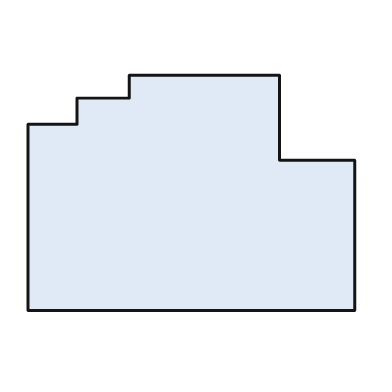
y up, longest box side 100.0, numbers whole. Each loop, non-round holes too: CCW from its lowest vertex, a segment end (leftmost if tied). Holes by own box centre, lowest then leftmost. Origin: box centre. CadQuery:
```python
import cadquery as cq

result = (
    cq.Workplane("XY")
    .moveTo(-50.0, -36.0)
    .lineTo(50.0, -36.0)
    .lineTo(50.0, 10.0)
    .lineTo(27.0, 10.0)
    .lineTo(27.0, 36.0)
    .lineTo(-19.0, 36.0)
    .lineTo(-19.0, 29.0)
    .lineTo(-35.0, 29.0)
    .lineTo(-35.0, 21.0)
    .lineTo(-50.0, 21.0)
    .close()
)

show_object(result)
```